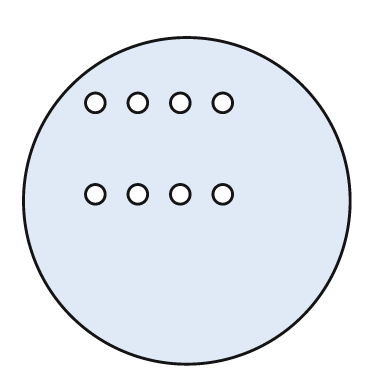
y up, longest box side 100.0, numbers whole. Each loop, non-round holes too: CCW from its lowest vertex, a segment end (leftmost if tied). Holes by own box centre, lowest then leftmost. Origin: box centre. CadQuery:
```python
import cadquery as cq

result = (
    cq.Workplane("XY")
    .moveTo(0.0, 0.0)
    .circle(50.0)
    .moveTo(-28.0, 2.0)
    .circle(3.0)
    .moveTo(-15.0, 2.0)
    .circle(3.0)
    .moveTo(-2.0, 2.0)
    .circle(3.0)
    .moveTo(11.0, 2.0)
    .circle(3.0)
    .moveTo(-28.0, 30.0)
    .circle(3.0)
    .moveTo(-15.0, 30.0)
    .circle(3.0)
    .moveTo(-2.0, 30.0)
    .circle(3.0)
    .moveTo(11.0, 30.0)
    .circle(3.0)
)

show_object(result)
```